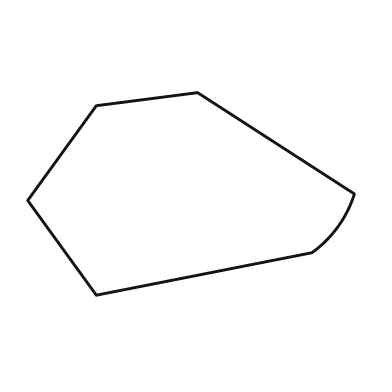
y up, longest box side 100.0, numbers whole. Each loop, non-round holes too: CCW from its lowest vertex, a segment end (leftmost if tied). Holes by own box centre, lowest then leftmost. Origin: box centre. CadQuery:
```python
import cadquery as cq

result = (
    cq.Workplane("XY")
    .moveTo(-29.0, -31.0)
    .lineTo(37.0, -18.0)
    .threePointArc((45.0, -10.0), (50.0, 0.0))
    .lineTo(2.0, 31.0)
    .lineTo(-29.0, 27.0)
    .lineTo(-50.0, -2.0)
    .close()
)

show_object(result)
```